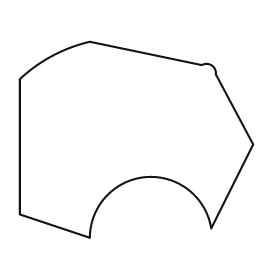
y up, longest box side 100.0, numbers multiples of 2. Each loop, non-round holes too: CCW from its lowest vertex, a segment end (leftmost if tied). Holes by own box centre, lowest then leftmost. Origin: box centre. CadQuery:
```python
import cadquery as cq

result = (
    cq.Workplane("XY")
    .moveTo(-20.0, -42.0)
    .threePointArc((4.0, -16.0), (32.0, -38.0))
    .lineTo(50.0, -2.0)
    .lineTo(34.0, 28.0)
    .threePointArc((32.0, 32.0), (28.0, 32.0))
    .lineTo(-20.0, 42.0)
    .threePointArc((-36.0, 36.0), (-50.0, 26.0))
    .lineTo(-50.0, -32.0)
    .close()
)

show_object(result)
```